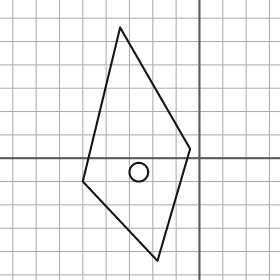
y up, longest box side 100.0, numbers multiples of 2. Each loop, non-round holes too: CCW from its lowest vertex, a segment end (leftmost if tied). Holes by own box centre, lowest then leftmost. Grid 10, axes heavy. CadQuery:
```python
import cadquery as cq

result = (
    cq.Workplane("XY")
    .moveTo(-18.0, -44.0)
    .lineTo(-4.0, 4.0)
    .lineTo(-34.0, 56.0)
    .lineTo(-50.0, -10.0)
    .close()
    .moveTo(-26.0, -6.0)
    .circle(4.0)
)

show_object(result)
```